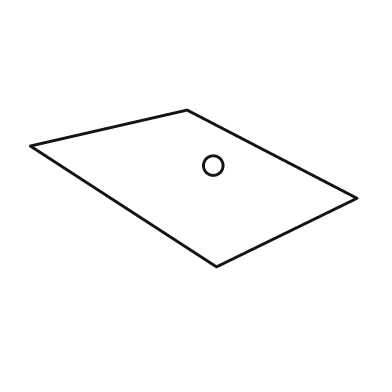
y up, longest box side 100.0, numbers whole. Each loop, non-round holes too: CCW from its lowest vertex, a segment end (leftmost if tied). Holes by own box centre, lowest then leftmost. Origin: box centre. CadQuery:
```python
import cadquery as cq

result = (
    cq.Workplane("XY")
    .moveTo(7.0, -24.0)
    .lineTo(50.0, -3.0)
    .lineTo(-2.0, 24.0)
    .lineTo(-50.0, 13.0)
    .close()
    .moveTo(6.0, 7.0)
    .circle(3.0)
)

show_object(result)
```